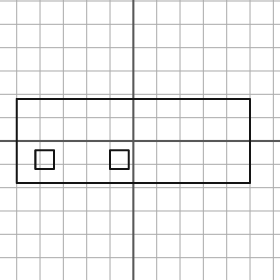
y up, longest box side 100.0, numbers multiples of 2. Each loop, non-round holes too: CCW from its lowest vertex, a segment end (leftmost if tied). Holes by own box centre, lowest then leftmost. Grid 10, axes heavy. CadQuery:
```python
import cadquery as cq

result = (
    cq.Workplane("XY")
    .moveTo(-50.0, -18.0)
    .lineTo(50.0, -18.0)
    .lineTo(50.0, 18.0)
    .lineTo(-50.0, 18.0)
    .close()
    .moveTo(-42.0, -12.0)
    .lineTo(-34.0, -12.0)
    .lineTo(-34.0, -4.0)
    .lineTo(-42.0, -4.0)
    .close()
    .moveTo(-10.0, -12.0)
    .lineTo(-2.0, -12.0)
    .lineTo(-2.0, -4.0)
    .lineTo(-10.0, -4.0)
    .close()
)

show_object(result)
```